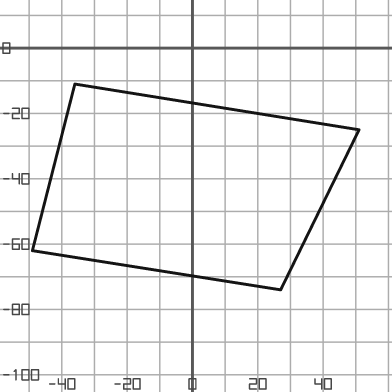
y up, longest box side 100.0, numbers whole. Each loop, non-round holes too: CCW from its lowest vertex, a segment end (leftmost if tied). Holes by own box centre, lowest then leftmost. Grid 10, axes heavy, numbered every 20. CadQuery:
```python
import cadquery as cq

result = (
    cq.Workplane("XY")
    .moveTo(27.0, -74.0)
    .lineTo(51.0, -25.0)
    .lineTo(-36.0, -11.0)
    .lineTo(-49.0, -62.0)
    .close()
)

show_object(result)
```